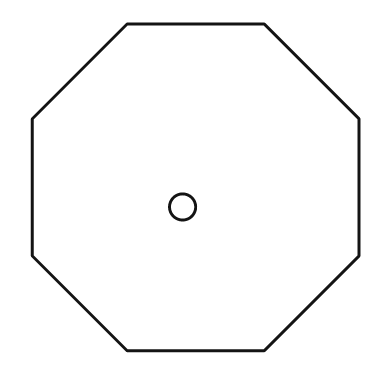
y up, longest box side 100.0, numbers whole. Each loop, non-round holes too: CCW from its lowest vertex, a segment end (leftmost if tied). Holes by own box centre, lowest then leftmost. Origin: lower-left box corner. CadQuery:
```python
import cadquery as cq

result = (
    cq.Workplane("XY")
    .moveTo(29.0, 0.0)
    .lineTo(71.0, 0.0)
    .lineTo(100.0, 29.0)
    .lineTo(100.0, 71.0)
    .lineTo(71.0, 100.0)
    .lineTo(29.0, 100.0)
    .lineTo(0.0, 71.0)
    .lineTo(0.0, 29.0)
    .close()
    .moveTo(46.0, 44.0)
    .circle(4.0)
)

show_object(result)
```